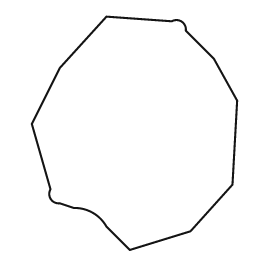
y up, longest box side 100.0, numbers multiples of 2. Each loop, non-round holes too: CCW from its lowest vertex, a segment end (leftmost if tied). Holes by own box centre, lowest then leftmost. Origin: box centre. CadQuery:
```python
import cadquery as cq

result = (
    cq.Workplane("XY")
    .moveTo(-2.0, -50.0)
    .lineTo(24.0, -42.0)
    .lineTo(42.0, -22.0)
    .lineTo(44.0, 14.0)
    .lineTo(34.0, 32.0)
    .lineTo(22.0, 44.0)
    .threePointArc((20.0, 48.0), (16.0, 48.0))
    .lineTo(-12.0, 50.0)
    .lineTo(-32.0, 28.0)
    .lineTo(-44.0, 4.0)
    .lineTo(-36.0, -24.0)
    .threePointArc((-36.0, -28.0), (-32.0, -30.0))
    .lineTo(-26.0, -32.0)
    .threePointArc((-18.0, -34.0), (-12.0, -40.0))
    .close()
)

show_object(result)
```